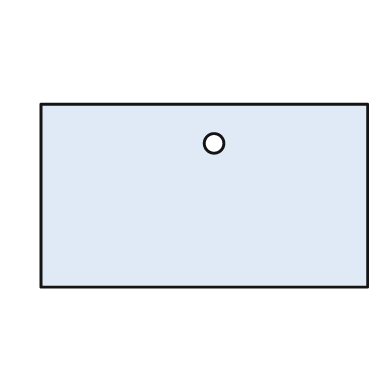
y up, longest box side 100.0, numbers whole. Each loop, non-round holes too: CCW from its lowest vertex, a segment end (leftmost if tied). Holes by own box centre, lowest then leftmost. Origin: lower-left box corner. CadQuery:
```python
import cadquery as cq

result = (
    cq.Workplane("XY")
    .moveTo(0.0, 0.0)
    .lineTo(100.0, 0.0)
    .lineTo(100.0, 56.0)
    .lineTo(0.0, 56.0)
    .close()
    .moveTo(53.0, 44.0)
    .circle(3.0)
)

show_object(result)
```